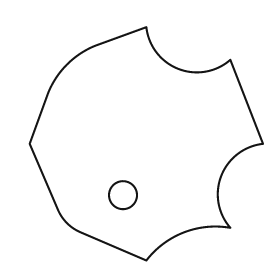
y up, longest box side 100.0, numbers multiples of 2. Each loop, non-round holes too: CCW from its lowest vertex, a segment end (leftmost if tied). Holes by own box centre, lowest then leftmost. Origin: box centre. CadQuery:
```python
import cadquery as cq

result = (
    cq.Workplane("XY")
    .moveTo(0.0, -50.0)
    .threePointArc((16.0, -38.0), (36.0, -36.0))
    .threePointArc((32.0, -14.0), (50.0, 0.0))
    .lineTo(36.0, 36.0)
    .threePointArc((14.0, 32.0), (0.0, 50.0))
    .lineTo(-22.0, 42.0)
    .threePointArc((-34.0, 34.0), (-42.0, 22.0))
    .lineTo(-50.0, 0.0)
    .lineTo(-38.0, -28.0)
    .threePointArc((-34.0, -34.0), (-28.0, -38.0))
    .close()
    .moveTo(-10.0, -22.0)
    .circle(6.0)
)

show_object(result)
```